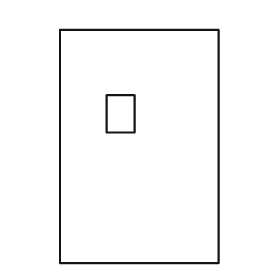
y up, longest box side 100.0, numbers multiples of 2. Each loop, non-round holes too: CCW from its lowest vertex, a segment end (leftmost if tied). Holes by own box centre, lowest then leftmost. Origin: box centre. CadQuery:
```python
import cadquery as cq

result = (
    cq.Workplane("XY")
    .moveTo(-34.0, -50.0)
    .lineTo(34.0, -50.0)
    .lineTo(34.0, 50.0)
    .lineTo(-34.0, 50.0)
    .close()
    .moveTo(-14.0, 6.0)
    .lineTo(-2.0, 6.0)
    .lineTo(-2.0, 22.0)
    .lineTo(-14.0, 22.0)
    .close()
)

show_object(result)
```